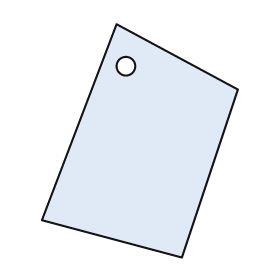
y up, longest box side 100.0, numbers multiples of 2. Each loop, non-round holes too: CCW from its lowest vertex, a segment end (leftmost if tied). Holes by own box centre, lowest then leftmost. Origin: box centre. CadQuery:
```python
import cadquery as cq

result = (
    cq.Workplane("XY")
    .moveTo(18.0, -50.0)
    .lineTo(42.0, 22.0)
    .lineTo(-10.0, 50.0)
    .lineTo(-42.0, -34.0)
    .close()
    .moveTo(-6.0, 32.0)
    .circle(4.0)
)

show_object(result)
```